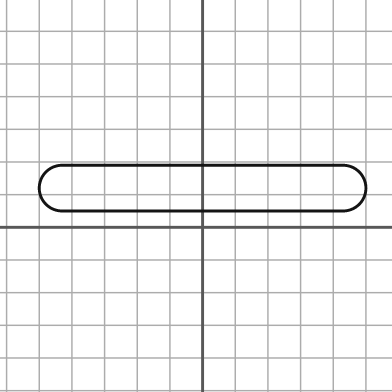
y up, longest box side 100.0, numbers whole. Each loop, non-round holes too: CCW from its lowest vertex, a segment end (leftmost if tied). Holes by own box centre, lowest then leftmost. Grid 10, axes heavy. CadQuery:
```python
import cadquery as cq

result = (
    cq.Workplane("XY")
    .moveTo(-43.0, 5.0)
    .lineTo(43.0, 5.0)
    .threePointArc((50.0, 12.0), (43.0, 19.0))
    .lineTo(-43.0, 19.0)
    .threePointArc((-50.0, 12.0), (-43.0, 5.0))
    .close()
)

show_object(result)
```